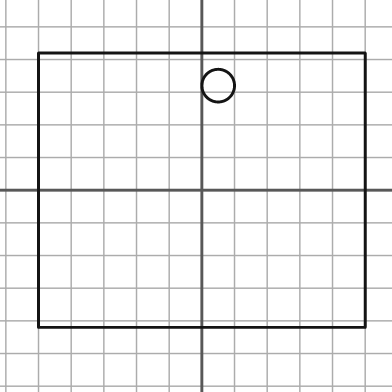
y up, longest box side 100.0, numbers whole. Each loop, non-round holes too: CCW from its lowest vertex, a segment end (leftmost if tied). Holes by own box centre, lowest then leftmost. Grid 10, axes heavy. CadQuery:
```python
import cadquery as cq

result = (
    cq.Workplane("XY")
    .moveTo(-50.0, -42.0)
    .lineTo(50.0, -42.0)
    .lineTo(50.0, 42.0)
    .lineTo(-50.0, 42.0)
    .close()
    .moveTo(5.0, 32.0)
    .circle(5.0)
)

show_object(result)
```